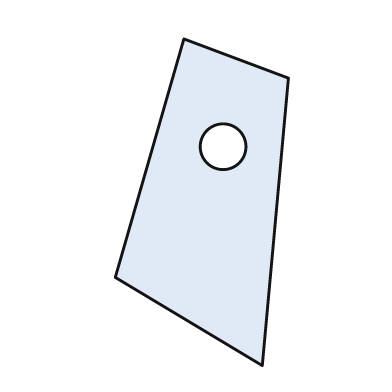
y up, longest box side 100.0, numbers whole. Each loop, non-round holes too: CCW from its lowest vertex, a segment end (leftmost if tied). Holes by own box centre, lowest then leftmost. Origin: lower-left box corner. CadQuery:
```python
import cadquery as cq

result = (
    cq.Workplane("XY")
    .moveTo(45.0, 0.0)
    .lineTo(53.0, 88.0)
    .lineTo(21.0, 100.0)
    .lineTo(0.0, 27.0)
    .close()
    .moveTo(33.0, 67.0)
    .circle(7.0)
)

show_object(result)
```